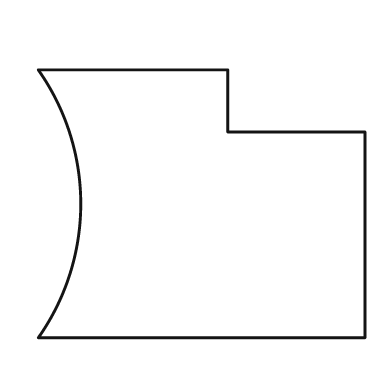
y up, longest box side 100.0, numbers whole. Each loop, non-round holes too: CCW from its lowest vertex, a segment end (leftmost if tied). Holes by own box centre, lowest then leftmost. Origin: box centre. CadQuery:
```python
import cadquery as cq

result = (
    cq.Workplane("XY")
    .moveTo(-50.0, -41.0)
    .lineTo(50.0, -41.0)
    .lineTo(50.0, 22.0)
    .lineTo(8.0, 22.0)
    .lineTo(8.0, 41.0)
    .lineTo(-50.0, 41.0)
    .threePointArc((-37.0, 0.0), (-50.0, -41.0))
    .close()
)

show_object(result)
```